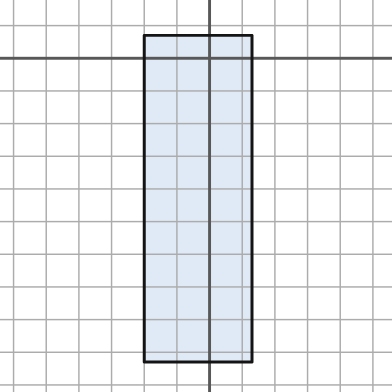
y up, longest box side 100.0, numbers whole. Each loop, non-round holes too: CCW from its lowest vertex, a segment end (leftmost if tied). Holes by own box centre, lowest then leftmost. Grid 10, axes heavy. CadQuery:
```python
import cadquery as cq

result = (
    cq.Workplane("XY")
    .moveTo(-20.0, -93.0)
    .lineTo(13.0, -93.0)
    .lineTo(13.0, 7.0)
    .lineTo(-20.0, 7.0)
    .close()
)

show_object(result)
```